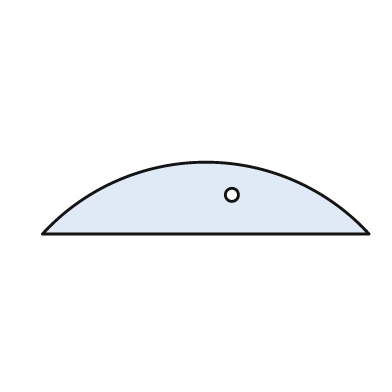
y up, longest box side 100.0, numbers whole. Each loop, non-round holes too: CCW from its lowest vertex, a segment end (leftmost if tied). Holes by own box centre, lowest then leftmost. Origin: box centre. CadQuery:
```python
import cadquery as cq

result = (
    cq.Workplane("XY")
    .moveTo(-50.0, -11.0)
    .lineTo(50.0, -11.0)
    .threePointArc((0.0, 11.0), (-50.0, -11.0))
    .close()
    .moveTo(8.0, 1.0)
    .circle(2.0)
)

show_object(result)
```